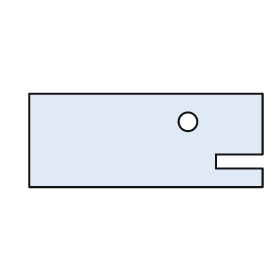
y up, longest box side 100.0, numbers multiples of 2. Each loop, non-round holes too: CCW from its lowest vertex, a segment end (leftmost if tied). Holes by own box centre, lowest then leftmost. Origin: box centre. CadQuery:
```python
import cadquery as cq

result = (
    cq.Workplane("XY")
    .moveTo(-50.0, -20.0)
    .lineTo(50.0, -20.0)
    .lineTo(50.0, -12.0)
    .lineTo(30.0, -12.0)
    .lineTo(30.0, -6.0)
    .lineTo(50.0, -6.0)
    .lineTo(50.0, 20.0)
    .lineTo(-50.0, 20.0)
    .close()
    .moveTo(18.0, 8.0)
    .circle(4.0)
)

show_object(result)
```